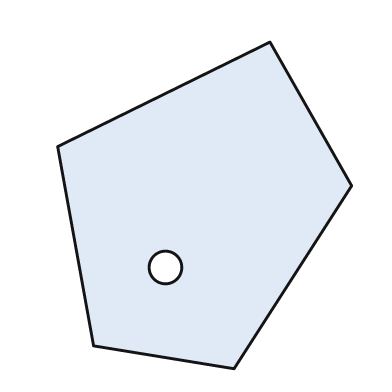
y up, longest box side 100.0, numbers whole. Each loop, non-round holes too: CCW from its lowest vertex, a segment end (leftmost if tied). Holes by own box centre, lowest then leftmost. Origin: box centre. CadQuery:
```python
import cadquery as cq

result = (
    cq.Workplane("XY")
    .moveTo(9.0, -50.0)
    .lineTo(45.0, 6.0)
    .lineTo(20.0, 50.0)
    .lineTo(-45.0, 18.0)
    .lineTo(-34.0, -43.0)
    .close()
    .moveTo(-12.0, -19.0)
    .circle(5.0)
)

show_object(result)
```